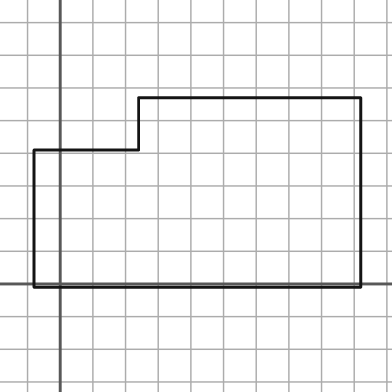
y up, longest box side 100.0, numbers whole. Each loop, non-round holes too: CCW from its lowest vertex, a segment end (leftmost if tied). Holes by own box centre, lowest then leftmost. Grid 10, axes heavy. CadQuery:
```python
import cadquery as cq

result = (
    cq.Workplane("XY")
    .moveTo(-8.0, -1.0)
    .lineTo(92.0, -1.0)
    .lineTo(92.0, 57.0)
    .lineTo(24.0, 57.0)
    .lineTo(24.0, 41.0)
    .lineTo(-8.0, 41.0)
    .close()
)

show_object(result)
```